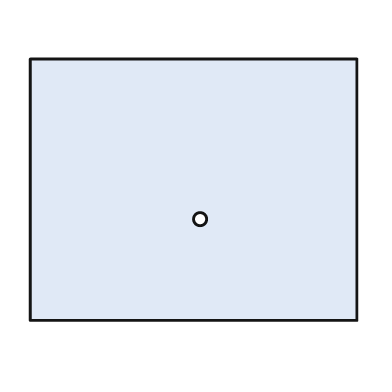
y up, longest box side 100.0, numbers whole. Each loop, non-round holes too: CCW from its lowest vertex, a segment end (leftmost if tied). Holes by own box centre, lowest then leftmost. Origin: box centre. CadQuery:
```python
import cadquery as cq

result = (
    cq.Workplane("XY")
    .moveTo(-50.0, -40.0)
    .lineTo(50.0, -40.0)
    .lineTo(50.0, 40.0)
    .lineTo(-50.0, 40.0)
    .close()
    .moveTo(2.0, -9.0)
    .circle(2.0)
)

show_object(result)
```